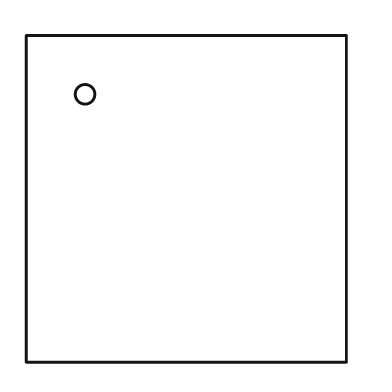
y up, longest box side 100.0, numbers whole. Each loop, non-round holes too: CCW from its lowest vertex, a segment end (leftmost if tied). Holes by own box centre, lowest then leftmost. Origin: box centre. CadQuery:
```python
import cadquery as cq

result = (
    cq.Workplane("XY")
    .moveTo(-49.0, -50.0)
    .lineTo(49.0, -50.0)
    .lineTo(49.0, 50.0)
    .lineTo(-49.0, 50.0)
    .close()
    .moveTo(-31.0, 32.0)
    .circle(3.0)
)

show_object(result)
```